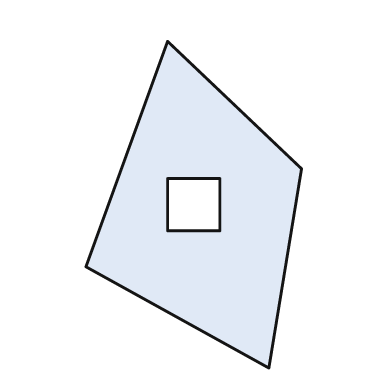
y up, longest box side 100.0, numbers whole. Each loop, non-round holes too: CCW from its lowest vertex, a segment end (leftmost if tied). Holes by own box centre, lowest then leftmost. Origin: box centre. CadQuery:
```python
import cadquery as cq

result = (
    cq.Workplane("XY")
    .moveTo(23.0, -50.0)
    .lineTo(33.0, 11.0)
    .lineTo(-8.0, 50.0)
    .lineTo(-33.0, -19.0)
    .close()
    .moveTo(-8.0, -8.0)
    .lineTo(8.0, -8.0)
    .lineTo(8.0, 8.0)
    .lineTo(-8.0, 8.0)
    .close()
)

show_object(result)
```